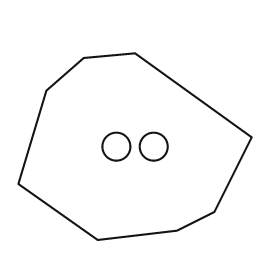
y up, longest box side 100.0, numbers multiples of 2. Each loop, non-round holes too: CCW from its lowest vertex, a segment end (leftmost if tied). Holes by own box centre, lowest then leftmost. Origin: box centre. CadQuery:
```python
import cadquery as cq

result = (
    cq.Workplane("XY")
    .moveTo(-16.0, -40.0)
    .lineTo(18.0, -36.0)
    .lineTo(34.0, -28.0)
    .lineTo(50.0, 4.0)
    .lineTo(0.0, 40.0)
    .lineTo(-22.0, 38.0)
    .lineTo(-38.0, 24.0)
    .lineTo(-50.0, -16.0)
    .close()
    .moveTo(-8.0, 0.0)
    .circle(6.0)
    .moveTo(8.0, 0.0)
    .circle(6.0)
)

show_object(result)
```